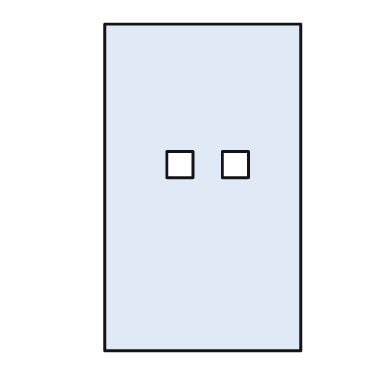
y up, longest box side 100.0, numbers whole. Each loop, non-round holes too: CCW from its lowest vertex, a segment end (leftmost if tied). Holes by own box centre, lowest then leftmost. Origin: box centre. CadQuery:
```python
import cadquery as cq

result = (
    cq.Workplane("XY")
    .moveTo(-30.0, -50.0)
    .lineTo(30.0, -50.0)
    .lineTo(30.0, 50.0)
    .lineTo(-30.0, 50.0)
    .close()
    .moveTo(-11.0, 3.0)
    .lineTo(-3.0, 3.0)
    .lineTo(-3.0, 11.0)
    .lineTo(-11.0, 11.0)
    .close()
    .moveTo(6.0, 3.0)
    .lineTo(14.0, 3.0)
    .lineTo(14.0, 11.0)
    .lineTo(6.0, 11.0)
    .close()
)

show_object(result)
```